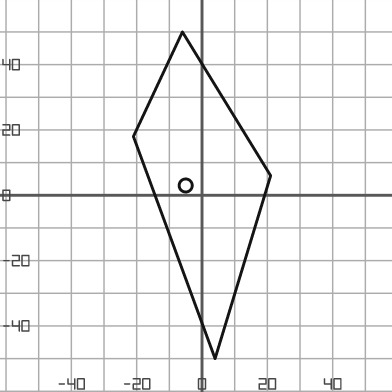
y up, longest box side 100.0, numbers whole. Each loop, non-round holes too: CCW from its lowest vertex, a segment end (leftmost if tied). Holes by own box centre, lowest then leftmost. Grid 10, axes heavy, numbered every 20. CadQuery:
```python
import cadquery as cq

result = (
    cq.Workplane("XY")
    .moveTo(4.0, -50.0)
    .lineTo(21.0, 6.0)
    .lineTo(-6.0, 50.0)
    .lineTo(-21.0, 18.0)
    .close()
    .moveTo(-5.0, 3.0)
    .circle(2.0)
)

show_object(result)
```